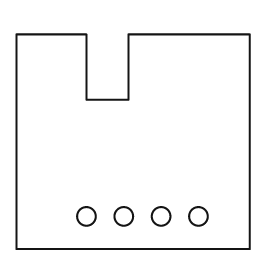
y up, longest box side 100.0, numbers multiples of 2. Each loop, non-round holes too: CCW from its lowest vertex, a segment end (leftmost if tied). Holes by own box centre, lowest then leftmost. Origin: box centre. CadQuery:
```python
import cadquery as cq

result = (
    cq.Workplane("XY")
    .moveTo(-50.0, -46.0)
    .lineTo(50.0, -46.0)
    .lineTo(50.0, 46.0)
    .lineTo(-2.0, 46.0)
    .lineTo(-2.0, 18.0)
    .lineTo(-20.0, 18.0)
    .lineTo(-20.0, 46.0)
    .lineTo(-50.0, 46.0)
    .close()
    .moveTo(-20.0, -32.0)
    .circle(4.0)
    .moveTo(-4.0, -32.0)
    .circle(4.0)
    .moveTo(12.0, -32.0)
    .circle(4.0)
    .moveTo(28.0, -32.0)
    .circle(4.0)
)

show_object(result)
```